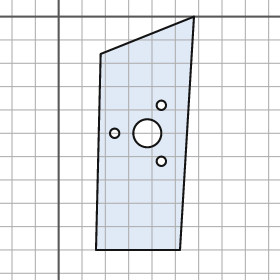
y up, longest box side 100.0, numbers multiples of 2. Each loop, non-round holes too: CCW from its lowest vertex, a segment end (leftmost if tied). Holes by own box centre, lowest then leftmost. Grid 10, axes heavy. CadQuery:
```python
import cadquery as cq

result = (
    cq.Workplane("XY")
    .moveTo(16.0, -100.0)
    .lineTo(52.0, -100.0)
    .lineTo(58.0, 0.0)
    .lineTo(18.0, -16.0)
    .close()
    .moveTo(44.0, -62.0)
    .circle(2.0)
    .moveTo(24.0, -50.0)
    .circle(2.0)
    .moveTo(38.0, -50.0)
    .circle(6.0)
    .moveTo(44.0, -38.0)
    .circle(2.0)
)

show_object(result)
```